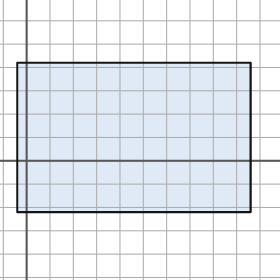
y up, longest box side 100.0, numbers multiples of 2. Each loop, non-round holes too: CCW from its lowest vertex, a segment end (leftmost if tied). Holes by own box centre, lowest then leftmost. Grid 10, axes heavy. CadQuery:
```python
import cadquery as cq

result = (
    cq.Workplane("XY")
    .moveTo(-4.0, -22.0)
    .lineTo(96.0, -22.0)
    .lineTo(96.0, 42.0)
    .lineTo(-4.0, 42.0)
    .close()
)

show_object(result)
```